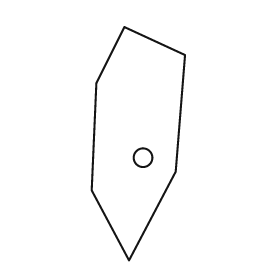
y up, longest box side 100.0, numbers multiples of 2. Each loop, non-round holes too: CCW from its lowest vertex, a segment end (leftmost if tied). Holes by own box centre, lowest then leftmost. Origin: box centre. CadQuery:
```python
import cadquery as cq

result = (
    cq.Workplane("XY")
    .moveTo(-4.0, -50.0)
    .lineTo(16.0, -12.0)
    .lineTo(20.0, 38.0)
    .lineTo(-6.0, 50.0)
    .lineTo(-18.0, 26.0)
    .lineTo(-20.0, -20.0)
    .close()
    .moveTo(2.0, -6.0)
    .circle(4.0)
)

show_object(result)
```